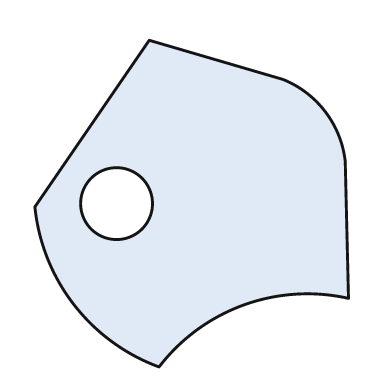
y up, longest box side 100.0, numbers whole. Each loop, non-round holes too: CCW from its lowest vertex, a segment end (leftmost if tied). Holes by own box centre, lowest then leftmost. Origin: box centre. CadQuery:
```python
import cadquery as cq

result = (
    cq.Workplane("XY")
    .moveTo(-10.0, -50.0)
    .threePointArc((16.0, -31.0), (48.0, -29.0))
    .lineTo(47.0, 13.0)
    .threePointArc((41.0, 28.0), (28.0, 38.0))
    .lineTo(-13.0, 50.0)
    .lineTo(-48.0, -1.0)
    .threePointArc((-36.0, -31.0), (-10.0, -50.0))
    .close()
    .moveTo(-23.0, 0.0)
    .circle(11.0)
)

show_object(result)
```